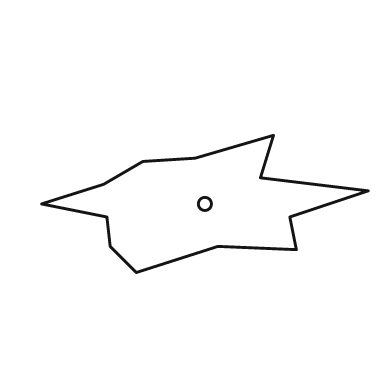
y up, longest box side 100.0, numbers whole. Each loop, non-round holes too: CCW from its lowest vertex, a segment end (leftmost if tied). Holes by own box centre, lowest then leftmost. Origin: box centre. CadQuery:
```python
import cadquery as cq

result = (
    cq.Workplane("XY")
    .moveTo(-21.0, -21.0)
    .lineTo(4.0, -13.0)
    .lineTo(28.0, -14.0)
    .lineTo(26.0, -4.0)
    .lineTo(50.0, 4.0)
    .lineTo(17.0, 8.0)
    .lineTo(21.0, 21.0)
    .lineTo(-3.0, 14.0)
    .lineTo(-19.0, 13.0)
    .lineTo(-31.0, 6.0)
    .lineTo(-50.0, 0.0)
    .lineTo(-30.0, -4.0)
    .lineTo(-29.0, -13.0)
    .close()
    .moveTo(0.0, 0.0)
    .circle(2.0)
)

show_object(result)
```